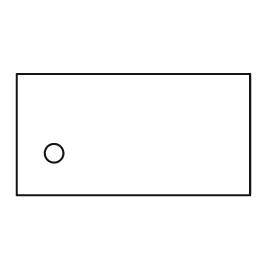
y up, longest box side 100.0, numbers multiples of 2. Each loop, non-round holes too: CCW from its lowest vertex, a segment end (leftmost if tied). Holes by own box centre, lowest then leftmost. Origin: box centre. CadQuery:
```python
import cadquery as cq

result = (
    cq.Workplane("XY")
    .moveTo(-50.0, -26.0)
    .lineTo(50.0, -26.0)
    .lineTo(50.0, 26.0)
    .lineTo(-50.0, 26.0)
    .close()
    .moveTo(-34.0, -8.0)
    .circle(4.0)
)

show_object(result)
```